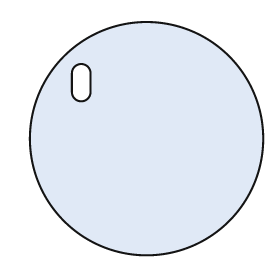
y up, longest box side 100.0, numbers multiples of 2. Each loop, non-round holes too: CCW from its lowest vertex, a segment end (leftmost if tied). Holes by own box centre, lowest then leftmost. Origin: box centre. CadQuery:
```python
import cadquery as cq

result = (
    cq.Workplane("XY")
    .moveTo(0.0, 0.0)
    .circle(50.0)
    .moveTo(-32.0, 20.0)
    .threePointArc((-28.0, 16.0), (-24.0, 20.0))
    .lineTo(-24.0, 28.0)
    .threePointArc((-28.0, 32.0), (-32.0, 28.0))
    .close()
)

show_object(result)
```